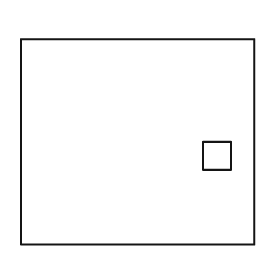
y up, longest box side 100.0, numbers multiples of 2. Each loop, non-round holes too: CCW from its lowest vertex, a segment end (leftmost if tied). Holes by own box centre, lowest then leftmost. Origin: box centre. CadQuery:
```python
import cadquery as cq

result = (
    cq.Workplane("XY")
    .moveTo(-50.0, -44.0)
    .lineTo(50.0, -44.0)
    .lineTo(50.0, 44.0)
    .lineTo(-50.0, 44.0)
    .close()
    .moveTo(28.0, -12.0)
    .lineTo(40.0, -12.0)
    .lineTo(40.0, 0.0)
    .lineTo(28.0, 0.0)
    .close()
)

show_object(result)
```